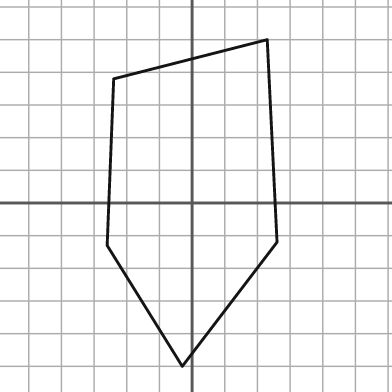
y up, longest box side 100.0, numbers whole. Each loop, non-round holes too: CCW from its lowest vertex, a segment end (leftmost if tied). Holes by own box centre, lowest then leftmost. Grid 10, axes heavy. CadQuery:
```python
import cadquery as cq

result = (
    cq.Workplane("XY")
    .moveTo(-3.0, -50.0)
    .lineTo(26.0, -12.0)
    .lineTo(23.0, 50.0)
    .lineTo(-24.0, 38.0)
    .lineTo(-26.0, -13.0)
    .close()
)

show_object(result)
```